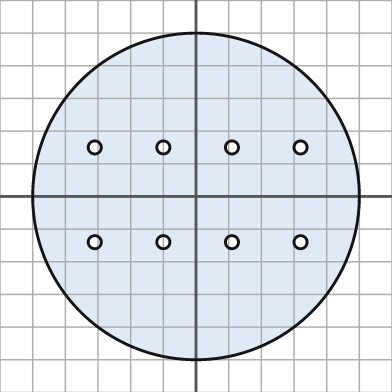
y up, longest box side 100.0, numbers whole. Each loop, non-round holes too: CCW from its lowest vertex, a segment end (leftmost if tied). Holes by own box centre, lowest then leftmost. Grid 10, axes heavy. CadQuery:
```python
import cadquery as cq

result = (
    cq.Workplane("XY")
    .moveTo(0.0, 0.0)
    .circle(50.0)
    .moveTo(-31.0, -14.0)
    .circle(2.0)
    .moveTo(-10.0, -14.0)
    .circle(2.0)
    .moveTo(11.0, -14.0)
    .circle(2.0)
    .moveTo(32.0, -14.0)
    .circle(2.0)
    .moveTo(-31.0, 15.0)
    .circle(2.0)
    .moveTo(-10.0, 15.0)
    .circle(2.0)
    .moveTo(11.0, 15.0)
    .circle(2.0)
    .moveTo(32.0, 15.0)
    .circle(2.0)
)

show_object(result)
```